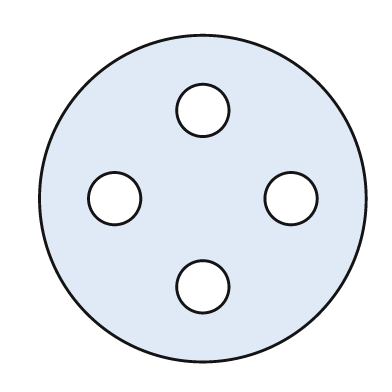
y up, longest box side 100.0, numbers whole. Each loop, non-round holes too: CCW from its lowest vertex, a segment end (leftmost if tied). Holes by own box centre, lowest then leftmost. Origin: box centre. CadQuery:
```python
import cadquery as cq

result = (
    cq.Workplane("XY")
    .moveTo(0.0, 0.0)
    .circle(50.0)
    .moveTo(0.0, -27.0)
    .circle(8.0)
    .moveTo(-27.0, 0.0)
    .circle(8.0)
    .moveTo(27.0, 0.0)
    .circle(8.0)
    .moveTo(0.0, 27.0)
    .circle(8.0)
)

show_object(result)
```